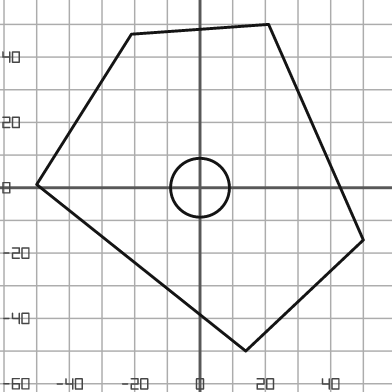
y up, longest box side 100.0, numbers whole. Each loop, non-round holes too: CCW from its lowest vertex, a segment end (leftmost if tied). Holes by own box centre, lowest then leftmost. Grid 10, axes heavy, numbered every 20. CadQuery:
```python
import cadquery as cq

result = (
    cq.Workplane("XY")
    .moveTo(14.0, -50.0)
    .lineTo(50.0, -16.0)
    .lineTo(21.0, 50.0)
    .lineTo(-21.0, 47.0)
    .lineTo(-50.0, 1.0)
    .close()
    .moveTo(0.0, 0.0)
    .circle(9.0)
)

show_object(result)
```